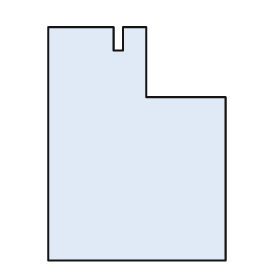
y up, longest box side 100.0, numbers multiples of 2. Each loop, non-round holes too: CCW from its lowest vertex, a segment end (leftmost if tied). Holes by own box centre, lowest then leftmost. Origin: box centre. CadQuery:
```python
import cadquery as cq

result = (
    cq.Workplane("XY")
    .moveTo(-38.0, -50.0)
    .lineTo(38.0, -50.0)
    .lineTo(38.0, 20.0)
    .lineTo(4.0, 20.0)
    .lineTo(4.0, 50.0)
    .lineTo(-6.0, 50.0)
    .lineTo(-6.0, 40.0)
    .lineTo(-10.0, 40.0)
    .lineTo(-10.0, 50.0)
    .lineTo(-38.0, 50.0)
    .close()
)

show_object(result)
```